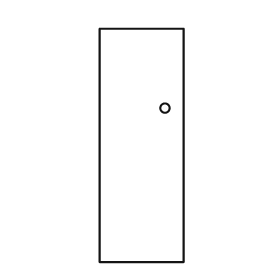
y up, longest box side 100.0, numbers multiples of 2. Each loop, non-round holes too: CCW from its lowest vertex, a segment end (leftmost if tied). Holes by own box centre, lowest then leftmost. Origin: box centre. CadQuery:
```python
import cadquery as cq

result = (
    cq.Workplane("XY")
    .moveTo(-18.0, -50.0)
    .lineTo(18.0, -50.0)
    .lineTo(18.0, 50.0)
    .lineTo(-18.0, 50.0)
    .close()
    .moveTo(10.0, 16.0)
    .circle(2.0)
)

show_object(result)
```